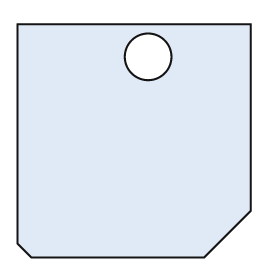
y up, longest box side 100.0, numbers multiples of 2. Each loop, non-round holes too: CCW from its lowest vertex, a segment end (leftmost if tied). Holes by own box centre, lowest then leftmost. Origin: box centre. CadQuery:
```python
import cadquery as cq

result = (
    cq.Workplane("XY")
    .moveTo(-44.0, -50.0)
    .lineTo(30.0, -50.0)
    .lineTo(50.0, -30.0)
    .lineTo(50.0, 50.0)
    .lineTo(-50.0, 50.0)
    .lineTo(-50.0, -44.0)
    .close()
    .moveTo(6.0, 36.0)
    .circle(10.0)
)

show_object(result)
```